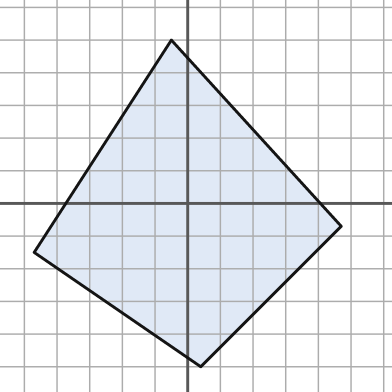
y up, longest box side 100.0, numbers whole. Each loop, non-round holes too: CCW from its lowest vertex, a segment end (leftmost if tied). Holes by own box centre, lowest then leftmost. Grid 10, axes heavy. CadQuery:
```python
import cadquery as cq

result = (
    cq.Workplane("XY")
    .moveTo(4.0, -50.0)
    .lineTo(47.0, -7.0)
    .lineTo(-5.0, 50.0)
    .lineTo(-47.0, -15.0)
    .close()
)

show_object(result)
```